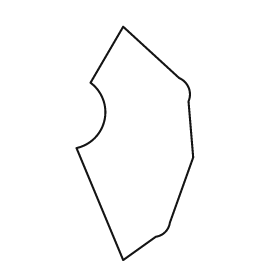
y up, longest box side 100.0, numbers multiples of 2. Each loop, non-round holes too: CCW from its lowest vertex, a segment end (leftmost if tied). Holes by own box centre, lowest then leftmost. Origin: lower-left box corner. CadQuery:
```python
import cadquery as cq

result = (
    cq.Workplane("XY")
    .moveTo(20.0, 0.0)
    .lineTo(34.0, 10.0)
    .threePointArc((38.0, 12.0), (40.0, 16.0))
    .lineTo(50.0, 44.0)
    .lineTo(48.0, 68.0)
    .threePointArc((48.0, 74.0), (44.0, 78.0))
    .lineTo(20.0, 100.0)
    .lineTo(6.0, 76.0)
    .threePointArc((12.0, 60.0), (0.0, 48.0))
    .close()
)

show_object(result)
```